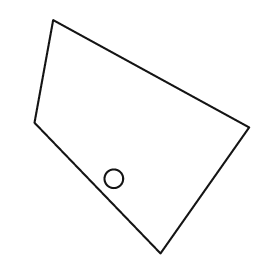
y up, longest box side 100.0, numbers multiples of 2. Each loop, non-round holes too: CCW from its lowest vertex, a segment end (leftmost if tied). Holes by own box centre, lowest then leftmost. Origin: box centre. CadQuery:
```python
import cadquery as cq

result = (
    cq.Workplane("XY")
    .moveTo(8.0, -50.0)
    .lineTo(46.0, 4.0)
    .lineTo(-38.0, 50.0)
    .lineTo(-46.0, 6.0)
    .close()
    .moveTo(-12.0, -18.0)
    .circle(4.0)
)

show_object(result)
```